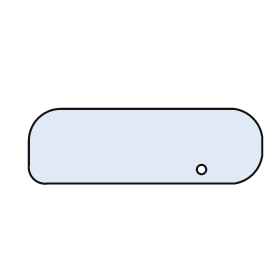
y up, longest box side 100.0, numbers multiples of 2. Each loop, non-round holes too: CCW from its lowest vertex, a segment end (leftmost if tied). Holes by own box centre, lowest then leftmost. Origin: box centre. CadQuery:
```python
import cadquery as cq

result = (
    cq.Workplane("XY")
    .moveTo(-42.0, -16.0)
    .lineTo(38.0, -16.0)
    .threePointArc((46.0, -12.0), (50.0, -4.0))
    .lineTo(50.0, 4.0)
    .threePointArc((46.0, 12.0), (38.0, 16.0))
    .lineTo(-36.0, 16.0)
    .threePointArc((-46.0, 12.0), (-50.0, 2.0))
    .lineTo(-50.0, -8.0)
    .threePointArc((-48.0, -14.0), (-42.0, -16.0))
    .close()
    .moveTo(24.0, -10.0)
    .circle(2.0)
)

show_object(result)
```